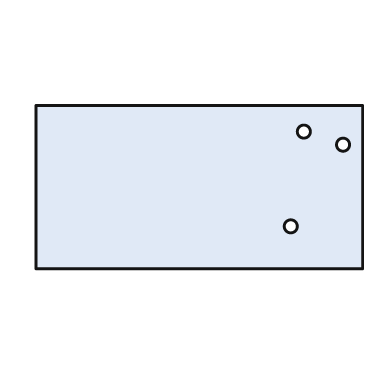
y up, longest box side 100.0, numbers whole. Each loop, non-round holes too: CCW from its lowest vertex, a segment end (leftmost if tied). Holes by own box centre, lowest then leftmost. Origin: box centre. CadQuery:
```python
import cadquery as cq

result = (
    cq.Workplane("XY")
    .moveTo(-50.0, -25.0)
    .lineTo(50.0, -25.0)
    .lineTo(50.0, 25.0)
    .lineTo(-50.0, 25.0)
    .close()
    .moveTo(28.0, -12.0)
    .circle(2.0)
    .moveTo(44.0, 13.0)
    .circle(2.0)
    .moveTo(32.0, 17.0)
    .circle(2.0)
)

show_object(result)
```